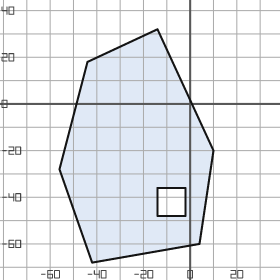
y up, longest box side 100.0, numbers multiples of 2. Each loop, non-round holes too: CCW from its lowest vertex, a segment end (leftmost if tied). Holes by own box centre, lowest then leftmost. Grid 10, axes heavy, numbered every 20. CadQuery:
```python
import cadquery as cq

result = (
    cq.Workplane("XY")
    .moveTo(-42.0, -68.0)
    .lineTo(4.0, -60.0)
    .lineTo(10.0, -20.0)
    .lineTo(-14.0, 32.0)
    .lineTo(-44.0, 18.0)
    .lineTo(-56.0, -28.0)
    .close()
    .moveTo(-14.0, -48.0)
    .lineTo(-2.0, -48.0)
    .lineTo(-2.0, -36.0)
    .lineTo(-14.0, -36.0)
    .close()
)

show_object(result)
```